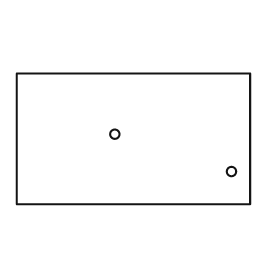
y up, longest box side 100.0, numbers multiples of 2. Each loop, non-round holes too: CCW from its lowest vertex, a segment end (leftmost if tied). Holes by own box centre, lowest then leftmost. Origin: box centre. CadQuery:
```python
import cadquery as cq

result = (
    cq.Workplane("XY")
    .moveTo(-50.0, -28.0)
    .lineTo(50.0, -28.0)
    .lineTo(50.0, 28.0)
    .lineTo(-50.0, 28.0)
    .close()
    .moveTo(42.0, -14.0)
    .circle(2.0)
    .moveTo(-8.0, 2.0)
    .circle(2.0)
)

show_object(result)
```